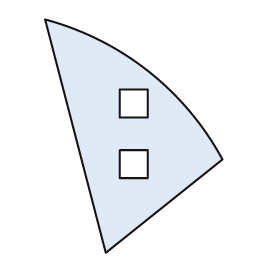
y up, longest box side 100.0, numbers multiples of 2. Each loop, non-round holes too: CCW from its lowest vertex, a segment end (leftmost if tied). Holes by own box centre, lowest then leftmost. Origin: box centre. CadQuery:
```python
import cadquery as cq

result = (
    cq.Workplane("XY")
    .moveTo(-12.0, -50.0)
    .lineTo(38.0, -10.0)
    .threePointArc((6.0, 28.0), (-38.0, 50.0))
    .close()
    .moveTo(-6.0, -18.0)
    .lineTo(6.0, -18.0)
    .lineTo(6.0, -6.0)
    .lineTo(-6.0, -6.0)
    .close()
    .moveTo(-6.0, 8.0)
    .lineTo(6.0, 8.0)
    .lineTo(6.0, 20.0)
    .lineTo(-6.0, 20.0)
    .close()
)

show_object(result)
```